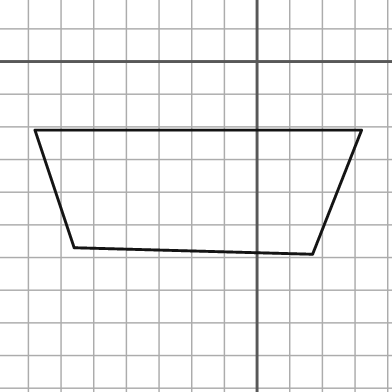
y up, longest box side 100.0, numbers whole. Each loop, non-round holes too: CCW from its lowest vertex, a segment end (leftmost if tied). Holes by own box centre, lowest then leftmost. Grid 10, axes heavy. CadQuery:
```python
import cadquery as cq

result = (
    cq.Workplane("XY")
    .moveTo(17.0, -59.0)
    .lineTo(32.0, -21.0)
    .lineTo(-68.0, -21.0)
    .lineTo(-56.0, -57.0)
    .close()
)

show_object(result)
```